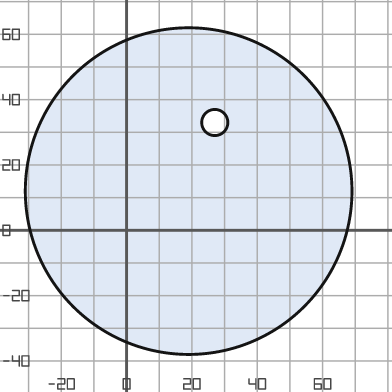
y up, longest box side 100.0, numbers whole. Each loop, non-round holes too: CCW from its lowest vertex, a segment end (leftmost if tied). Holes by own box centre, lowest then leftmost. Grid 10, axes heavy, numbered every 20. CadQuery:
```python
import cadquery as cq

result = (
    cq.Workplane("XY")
    .moveTo(19.0, 12.0)
    .circle(50.0)
    .moveTo(27.0, 33.0)
    .circle(4.0)
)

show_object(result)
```